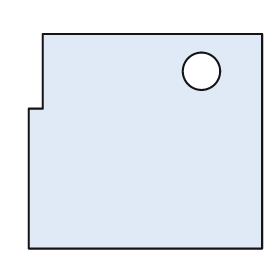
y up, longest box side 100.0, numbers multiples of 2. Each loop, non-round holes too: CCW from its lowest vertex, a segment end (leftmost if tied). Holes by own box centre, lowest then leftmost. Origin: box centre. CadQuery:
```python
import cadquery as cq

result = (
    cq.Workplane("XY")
    .moveTo(-50.0, -46.0)
    .lineTo(50.0, -46.0)
    .lineTo(50.0, 46.0)
    .lineTo(-44.0, 46.0)
    .lineTo(-44.0, 14.0)
    .lineTo(-50.0, 14.0)
    .close()
    .moveTo(24.0, 30.0)
    .circle(8.0)
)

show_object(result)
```